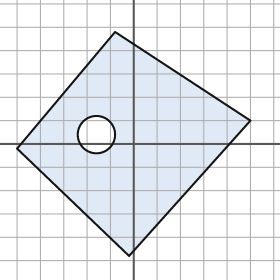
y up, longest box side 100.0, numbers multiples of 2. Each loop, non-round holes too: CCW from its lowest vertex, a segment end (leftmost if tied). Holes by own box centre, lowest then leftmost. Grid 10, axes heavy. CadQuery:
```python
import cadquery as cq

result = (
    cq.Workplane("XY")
    .moveTo(-2.0, -48.0)
    .lineTo(50.0, 10.0)
    .lineTo(-8.0, 48.0)
    .lineTo(-50.0, -2.0)
    .close()
    .moveTo(-16.0, 4.0)
    .circle(8.0)
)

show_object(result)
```